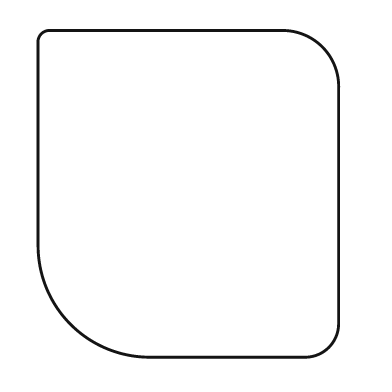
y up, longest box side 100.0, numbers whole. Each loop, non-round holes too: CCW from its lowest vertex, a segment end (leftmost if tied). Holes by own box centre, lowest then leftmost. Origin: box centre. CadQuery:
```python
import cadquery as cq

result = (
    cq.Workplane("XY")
    .moveTo(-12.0, -50.0)
    .lineTo(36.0, -50.0)
    .threePointArc((43.0, -47.0), (46.0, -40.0))
    .lineTo(46.0, 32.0)
    .threePointArc((41.0, 45.0), (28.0, 50.0))
    .lineTo(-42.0, 50.0)
    .threePointArc((-45.0, 49.0), (-46.0, 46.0))
    .lineTo(-46.0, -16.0)
    .threePointArc((-36.0, -40.0), (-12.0, -50.0))
    .close()
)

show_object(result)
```